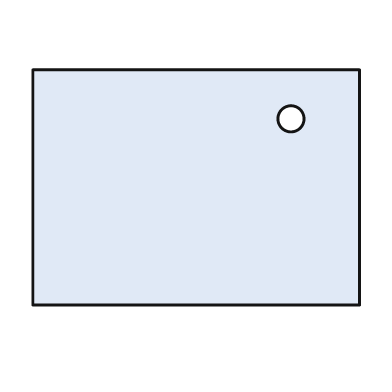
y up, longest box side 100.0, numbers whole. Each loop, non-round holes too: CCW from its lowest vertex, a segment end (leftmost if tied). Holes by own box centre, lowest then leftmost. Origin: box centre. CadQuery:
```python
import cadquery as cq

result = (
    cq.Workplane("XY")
    .moveTo(-50.0, -36.0)
    .lineTo(50.0, -36.0)
    .lineTo(50.0, 36.0)
    .lineTo(-50.0, 36.0)
    .close()
    .moveTo(29.0, 21.0)
    .circle(4.0)
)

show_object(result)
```